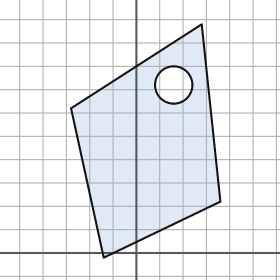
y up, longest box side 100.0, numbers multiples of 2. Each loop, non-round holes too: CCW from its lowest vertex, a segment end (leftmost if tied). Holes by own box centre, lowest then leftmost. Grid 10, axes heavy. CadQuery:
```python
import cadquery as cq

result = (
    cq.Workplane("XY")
    .moveTo(-14.0, -2.0)
    .lineTo(36.0, 22.0)
    .lineTo(28.0, 98.0)
    .lineTo(-28.0, 62.0)
    .close()
    .moveTo(16.0, 72.0)
    .circle(8.0)
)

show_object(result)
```